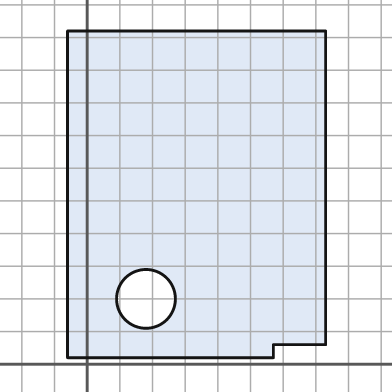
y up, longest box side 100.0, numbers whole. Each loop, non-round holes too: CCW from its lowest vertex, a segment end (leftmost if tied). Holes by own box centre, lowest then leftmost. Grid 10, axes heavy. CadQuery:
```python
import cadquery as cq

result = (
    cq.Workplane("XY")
    .moveTo(-6.0, 2.0)
    .lineTo(57.0, 2.0)
    .lineTo(57.0, 6.0)
    .lineTo(73.0, 6.0)
    .lineTo(73.0, 102.0)
    .lineTo(-6.0, 102.0)
    .close()
    .moveTo(18.0, 20.0)
    .circle(9.0)
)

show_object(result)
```